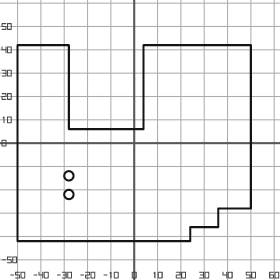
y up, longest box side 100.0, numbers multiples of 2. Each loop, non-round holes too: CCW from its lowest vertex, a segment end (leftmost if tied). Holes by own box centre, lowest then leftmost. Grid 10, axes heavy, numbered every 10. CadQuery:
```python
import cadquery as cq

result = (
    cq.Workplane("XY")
    .moveTo(-50.0, -42.0)
    .lineTo(24.0, -42.0)
    .lineTo(24.0, -36.0)
    .lineTo(36.0, -36.0)
    .lineTo(36.0, -28.0)
    .lineTo(50.0, -28.0)
    .lineTo(50.0, 42.0)
    .lineTo(4.0, 42.0)
    .lineTo(4.0, 6.0)
    .lineTo(-28.0, 6.0)
    .lineTo(-28.0, 42.0)
    .lineTo(-50.0, 42.0)
    .close()
    .moveTo(-28.0, -22.0)
    .circle(2.0)
    .moveTo(-28.0, -14.0)
    .circle(2.0)
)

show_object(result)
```